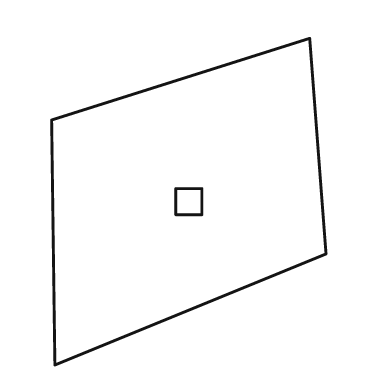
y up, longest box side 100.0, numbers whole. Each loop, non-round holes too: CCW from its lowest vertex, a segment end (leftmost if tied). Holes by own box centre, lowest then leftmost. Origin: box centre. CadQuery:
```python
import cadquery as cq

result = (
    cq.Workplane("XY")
    .moveTo(-41.0, -50.0)
    .lineTo(42.0, -16.0)
    .lineTo(37.0, 50.0)
    .lineTo(-42.0, 25.0)
    .close()
    .moveTo(-4.0, -4.0)
    .lineTo(4.0, -4.0)
    .lineTo(4.0, 4.0)
    .lineTo(-4.0, 4.0)
    .close()
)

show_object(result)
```